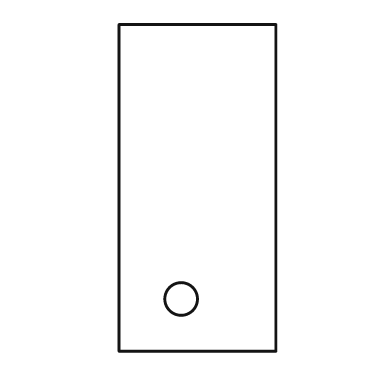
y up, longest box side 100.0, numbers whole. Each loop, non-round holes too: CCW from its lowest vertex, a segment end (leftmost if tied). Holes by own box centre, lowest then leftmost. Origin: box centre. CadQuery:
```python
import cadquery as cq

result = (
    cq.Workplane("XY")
    .moveTo(-24.0, -50.0)
    .lineTo(24.0, -50.0)
    .lineTo(24.0, 50.0)
    .lineTo(-24.0, 50.0)
    .close()
    .moveTo(-5.0, -34.0)
    .circle(5.0)
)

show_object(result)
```